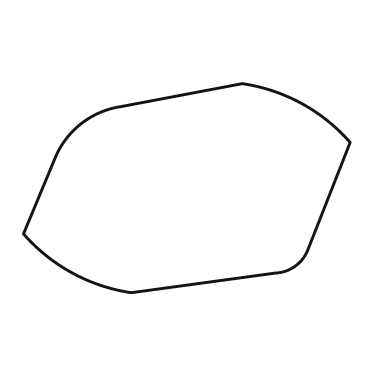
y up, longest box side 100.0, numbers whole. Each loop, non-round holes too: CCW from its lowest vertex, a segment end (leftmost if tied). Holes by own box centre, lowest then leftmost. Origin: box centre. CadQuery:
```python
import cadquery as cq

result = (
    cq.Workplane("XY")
    .moveTo(-17.0, -32.0)
    .lineTo(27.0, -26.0)
    .threePointArc((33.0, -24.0), (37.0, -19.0))
    .lineTo(50.0, 14.0)
    .threePointArc((35.0, 26.0), (17.0, 32.0))
    .lineTo(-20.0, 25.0)
    .threePointArc((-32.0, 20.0), (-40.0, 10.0))
    .lineTo(-50.0, -14.0)
    .threePointArc((-35.0, -26.0), (-17.0, -32.0))
    .close()
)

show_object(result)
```